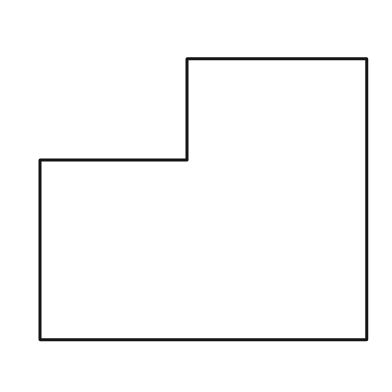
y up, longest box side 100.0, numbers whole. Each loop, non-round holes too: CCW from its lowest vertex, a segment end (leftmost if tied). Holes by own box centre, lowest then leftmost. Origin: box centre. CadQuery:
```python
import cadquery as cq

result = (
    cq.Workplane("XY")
    .moveTo(-50.0, -43.0)
    .lineTo(50.0, -43.0)
    .lineTo(50.0, 43.0)
    .lineTo(-5.0, 43.0)
    .lineTo(-5.0, 12.0)
    .lineTo(-50.0, 12.0)
    .close()
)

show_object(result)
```